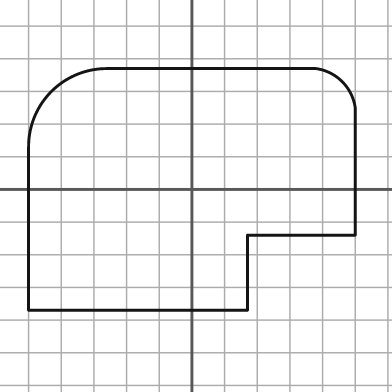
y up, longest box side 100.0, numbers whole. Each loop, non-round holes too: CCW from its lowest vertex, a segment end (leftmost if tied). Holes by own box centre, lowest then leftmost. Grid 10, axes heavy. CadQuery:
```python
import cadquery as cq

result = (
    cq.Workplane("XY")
    .moveTo(-50.0, -37.0)
    .lineTo(17.0, -37.0)
    .lineTo(17.0, -14.0)
    .lineTo(50.0, -14.0)
    .lineTo(50.0, 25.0)
    .threePointArc((46.0, 33.0), (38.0, 37.0))
    .lineTo(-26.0, 37.0)
    .threePointArc((-43.0, 30.0), (-50.0, 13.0))
    .close()
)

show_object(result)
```